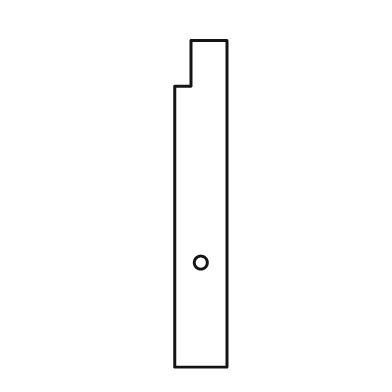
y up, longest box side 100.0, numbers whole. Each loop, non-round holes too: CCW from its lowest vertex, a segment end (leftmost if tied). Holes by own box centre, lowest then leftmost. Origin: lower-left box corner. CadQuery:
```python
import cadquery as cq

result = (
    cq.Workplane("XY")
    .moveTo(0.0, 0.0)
    .lineTo(16.0, 0.0)
    .lineTo(16.0, 100.0)
    .lineTo(5.0, 100.0)
    .lineTo(5.0, 86.0)
    .lineTo(0.0, 86.0)
    .close()
    .moveTo(8.0, 32.0)
    .circle(2.0)
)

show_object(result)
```